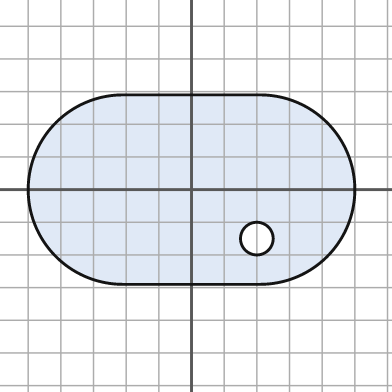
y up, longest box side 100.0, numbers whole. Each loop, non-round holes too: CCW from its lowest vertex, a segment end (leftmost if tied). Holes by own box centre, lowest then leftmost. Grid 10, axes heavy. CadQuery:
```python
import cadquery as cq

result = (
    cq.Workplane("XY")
    .moveTo(-21.0, -29.0)
    .lineTo(21.0, -29.0)
    .threePointArc((50.0, 0.0), (21.0, 29.0))
    .lineTo(-21.0, 29.0)
    .threePointArc((-50.0, 0.0), (-21.0, -29.0))
    .close()
    .moveTo(20.0, -15.0)
    .circle(5.0)
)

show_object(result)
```